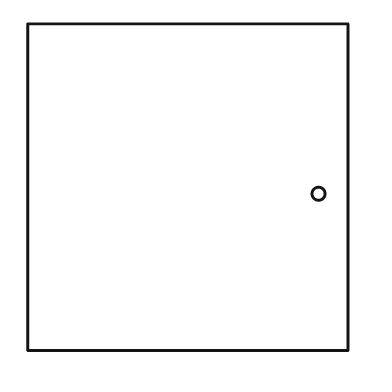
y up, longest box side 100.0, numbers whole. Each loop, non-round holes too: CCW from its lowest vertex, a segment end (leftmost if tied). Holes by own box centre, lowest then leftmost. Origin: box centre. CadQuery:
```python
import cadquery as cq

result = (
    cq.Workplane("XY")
    .moveTo(-49.0, -50.0)
    .lineTo(49.0, -50.0)
    .lineTo(49.0, 50.0)
    .lineTo(-49.0, 50.0)
    .close()
    .moveTo(40.0, -2.0)
    .circle(2.0)
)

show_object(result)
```